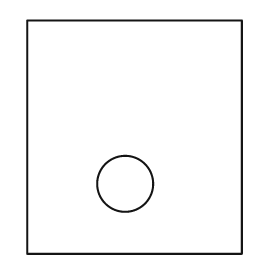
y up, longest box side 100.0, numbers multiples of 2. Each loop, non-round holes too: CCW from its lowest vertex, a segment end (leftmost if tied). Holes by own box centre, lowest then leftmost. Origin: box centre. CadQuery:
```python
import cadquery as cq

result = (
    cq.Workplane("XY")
    .moveTo(-46.0, -50.0)
    .lineTo(46.0, -50.0)
    .lineTo(46.0, 50.0)
    .lineTo(-46.0, 50.0)
    .close()
    .moveTo(-4.0, -20.0)
    .circle(12.0)
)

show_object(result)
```